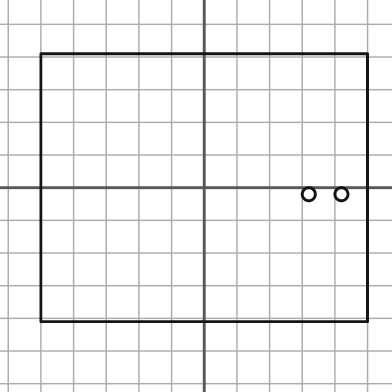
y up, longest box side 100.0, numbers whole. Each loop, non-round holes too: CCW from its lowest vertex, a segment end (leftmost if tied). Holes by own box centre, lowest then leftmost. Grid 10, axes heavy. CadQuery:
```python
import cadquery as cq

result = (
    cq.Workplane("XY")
    .moveTo(-50.0, -41.0)
    .lineTo(50.0, -41.0)
    .lineTo(50.0, 41.0)
    .lineTo(-50.0, 41.0)
    .close()
    .moveTo(32.0, -2.0)
    .circle(2.0)
    .moveTo(42.0, -2.0)
    .circle(2.0)
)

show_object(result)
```